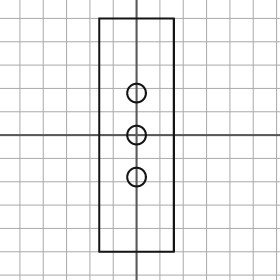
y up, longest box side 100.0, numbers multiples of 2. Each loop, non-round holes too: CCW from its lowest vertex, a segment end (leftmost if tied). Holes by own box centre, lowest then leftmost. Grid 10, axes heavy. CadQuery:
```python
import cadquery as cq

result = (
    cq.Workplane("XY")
    .moveTo(-16.0, -50.0)
    .lineTo(16.0, -50.0)
    .lineTo(16.0, 50.0)
    .lineTo(-16.0, 50.0)
    .close()
    .moveTo(0.0, -18.0)
    .circle(4.0)
    .moveTo(0.0, 0.0)
    .circle(4.0)
    .moveTo(0.0, 18.0)
    .circle(4.0)
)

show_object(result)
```